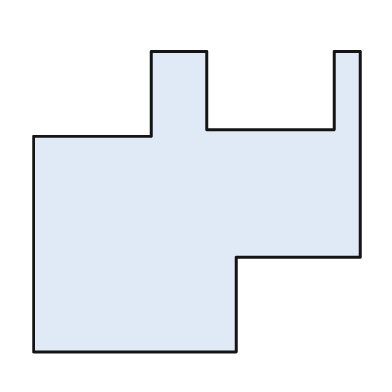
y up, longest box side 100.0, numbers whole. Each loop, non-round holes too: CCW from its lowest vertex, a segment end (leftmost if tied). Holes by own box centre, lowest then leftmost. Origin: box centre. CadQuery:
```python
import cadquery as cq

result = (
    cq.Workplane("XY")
    .moveTo(-50.0, -46.0)
    .lineTo(12.0, -46.0)
    .lineTo(12.0, -17.0)
    .lineTo(50.0, -17.0)
    .lineTo(50.0, 46.0)
    .lineTo(42.0, 46.0)
    .lineTo(42.0, 22.0)
    .lineTo(3.0, 22.0)
    .lineTo(3.0, 46.0)
    .lineTo(-14.0, 46.0)
    .lineTo(-14.0, 20.0)
    .lineTo(-50.0, 20.0)
    .close()
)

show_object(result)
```